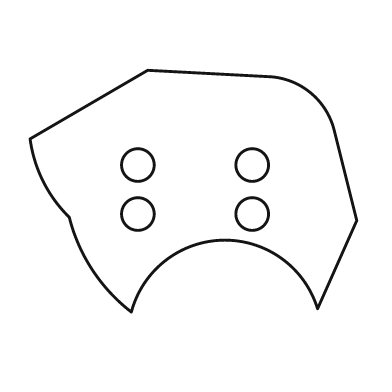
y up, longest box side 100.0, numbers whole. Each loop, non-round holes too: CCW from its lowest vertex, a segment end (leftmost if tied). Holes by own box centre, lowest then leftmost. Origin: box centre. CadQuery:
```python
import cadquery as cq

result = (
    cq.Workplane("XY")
    .moveTo(-19.0, -37.0)
    .threePointArc((9.0, -15.0), (38.0, -36.0))
    .lineTo(50.0, -9.0)
    .lineTo(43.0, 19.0)
    .threePointArc((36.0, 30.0), (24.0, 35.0))
    .lineTo(-14.0, 37.0)
    .lineTo(-50.0, 16.0)
    .threePointArc((-46.0, 3.0), (-38.0, -8.0))
    .threePointArc((-31.0, -24.0), (-19.0, -37.0))
    .close()
    .moveTo(-17.0, -7.0)
    .circle(5.0)
    .moveTo(18.0, -7.0)
    .circle(5.0)
    .moveTo(-17.0, 8.0)
    .circle(5.0)
    .moveTo(18.0, 8.0)
    .circle(5.0)
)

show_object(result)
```